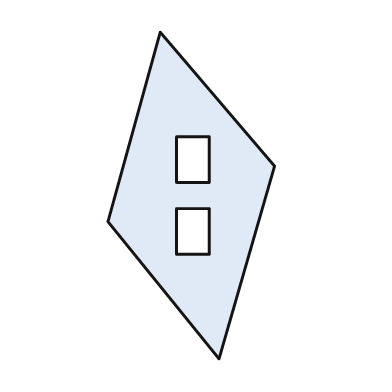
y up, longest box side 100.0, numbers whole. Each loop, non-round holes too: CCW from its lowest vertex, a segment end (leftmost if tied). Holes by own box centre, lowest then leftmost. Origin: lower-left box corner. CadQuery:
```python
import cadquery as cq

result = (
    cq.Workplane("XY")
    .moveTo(34.0, 0.0)
    .lineTo(51.0, 59.0)
    .lineTo(16.0, 100.0)
    .lineTo(0.0, 42.0)
    .close()
    .moveTo(21.0, 32.0)
    .lineTo(31.0, 32.0)
    .lineTo(31.0, 46.0)
    .lineTo(21.0, 46.0)
    .close()
    .moveTo(21.0, 54.0)
    .lineTo(31.0, 54.0)
    .lineTo(31.0, 68.0)
    .lineTo(21.0, 68.0)
    .close()
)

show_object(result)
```